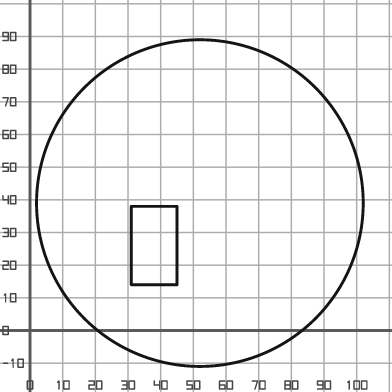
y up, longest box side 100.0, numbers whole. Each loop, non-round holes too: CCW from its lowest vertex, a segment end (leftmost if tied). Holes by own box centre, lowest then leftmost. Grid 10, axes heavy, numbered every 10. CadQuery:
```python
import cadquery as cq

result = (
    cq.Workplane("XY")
    .moveTo(52.0, 39.0)
    .circle(50.0)
    .moveTo(31.0, 14.0)
    .lineTo(45.0, 14.0)
    .lineTo(45.0, 38.0)
    .lineTo(31.0, 38.0)
    .close()
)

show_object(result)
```